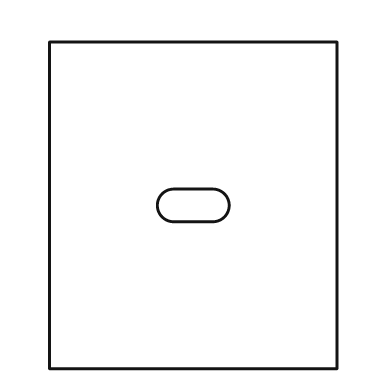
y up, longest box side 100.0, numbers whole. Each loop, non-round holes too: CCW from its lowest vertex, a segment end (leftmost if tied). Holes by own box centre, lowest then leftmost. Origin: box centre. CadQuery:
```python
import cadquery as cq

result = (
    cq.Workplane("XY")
    .moveTo(-44.0, -50.0)
    .lineTo(44.0, -50.0)
    .lineTo(44.0, 50.0)
    .lineTo(-44.0, 50.0)
    .close()
    .moveTo(-6.0, -5.0)
    .lineTo(6.0, -5.0)
    .threePointArc((11.0, 0.0), (6.0, 5.0))
    .lineTo(-6.0, 5.0)
    .threePointArc((-11.0, 0.0), (-6.0, -5.0))
    .close()
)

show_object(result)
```